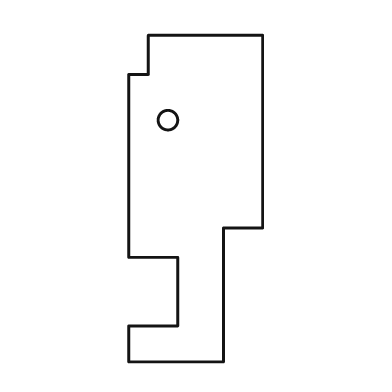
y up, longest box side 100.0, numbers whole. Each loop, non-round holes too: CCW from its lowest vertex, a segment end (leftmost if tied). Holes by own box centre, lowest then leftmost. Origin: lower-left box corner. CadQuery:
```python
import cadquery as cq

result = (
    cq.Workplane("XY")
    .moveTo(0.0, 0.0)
    .lineTo(29.0, 0.0)
    .lineTo(29.0, 41.0)
    .lineTo(41.0, 41.0)
    .lineTo(41.0, 100.0)
    .lineTo(6.0, 100.0)
    .lineTo(6.0, 88.0)
    .lineTo(0.0, 88.0)
    .lineTo(0.0, 32.0)
    .lineTo(15.0, 32.0)
    .lineTo(15.0, 11.0)
    .lineTo(0.0, 11.0)
    .close()
    .moveTo(12.0, 74.0)
    .circle(3.0)
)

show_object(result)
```